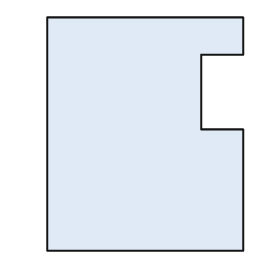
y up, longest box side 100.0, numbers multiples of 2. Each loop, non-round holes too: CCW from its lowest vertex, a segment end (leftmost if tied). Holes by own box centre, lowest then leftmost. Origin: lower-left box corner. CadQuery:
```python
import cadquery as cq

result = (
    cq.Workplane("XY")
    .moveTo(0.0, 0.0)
    .lineTo(84.0, 0.0)
    .lineTo(84.0, 52.0)
    .lineTo(66.0, 52.0)
    .lineTo(66.0, 84.0)
    .lineTo(84.0, 84.0)
    .lineTo(84.0, 100.0)
    .lineTo(0.0, 100.0)
    .close()
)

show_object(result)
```